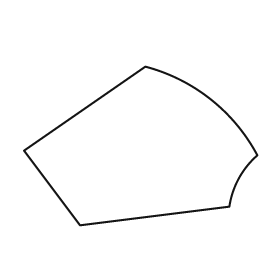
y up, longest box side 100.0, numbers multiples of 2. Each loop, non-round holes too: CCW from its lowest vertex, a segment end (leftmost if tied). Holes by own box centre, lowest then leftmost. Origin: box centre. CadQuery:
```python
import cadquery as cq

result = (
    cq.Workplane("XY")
    .moveTo(-26.0, -34.0)
    .lineTo(38.0, -26.0)
    .threePointArc((42.0, -14.0), (50.0, -4.0))
    .threePointArc((30.0, 20.0), (2.0, 34.0))
    .lineTo(-50.0, -2.0)
    .close()
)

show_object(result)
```